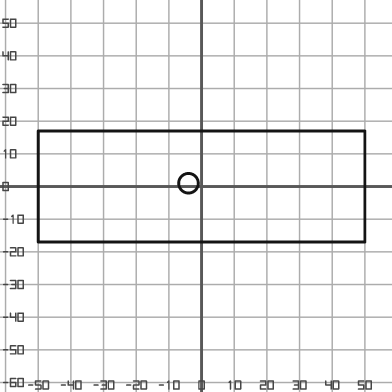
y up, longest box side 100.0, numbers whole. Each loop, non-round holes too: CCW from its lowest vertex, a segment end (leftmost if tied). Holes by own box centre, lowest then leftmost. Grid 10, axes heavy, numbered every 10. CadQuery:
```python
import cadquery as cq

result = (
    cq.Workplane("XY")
    .moveTo(-50.0, -17.0)
    .lineTo(50.0, -17.0)
    .lineTo(50.0, 17.0)
    .lineTo(-50.0, 17.0)
    .close()
    .moveTo(-4.0, 1.0)
    .circle(3.0)
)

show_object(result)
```